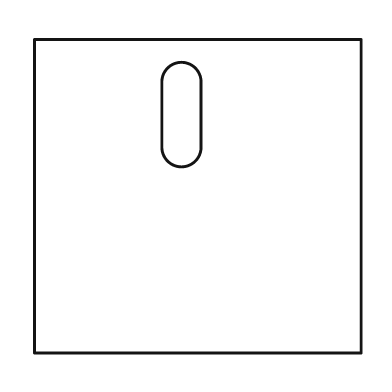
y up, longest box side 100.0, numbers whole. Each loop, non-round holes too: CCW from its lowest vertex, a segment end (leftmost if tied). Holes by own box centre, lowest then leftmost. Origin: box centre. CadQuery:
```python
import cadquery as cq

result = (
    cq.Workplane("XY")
    .moveTo(-50.0, -48.0)
    .lineTo(50.0, -48.0)
    .lineTo(50.0, 48.0)
    .lineTo(-50.0, 48.0)
    .close()
    .moveTo(-11.0, 15.0)
    .threePointArc((-5.0, 9.0), (1.0, 15.0))
    .lineTo(1.0, 35.0)
    .threePointArc((-5.0, 41.0), (-11.0, 35.0))
    .close()
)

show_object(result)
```